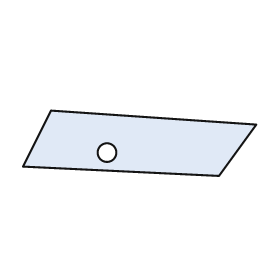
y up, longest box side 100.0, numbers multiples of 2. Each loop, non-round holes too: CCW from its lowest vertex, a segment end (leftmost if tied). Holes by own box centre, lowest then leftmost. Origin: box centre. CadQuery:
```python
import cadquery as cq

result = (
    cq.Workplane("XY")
    .moveTo(34.0, -14.0)
    .lineTo(50.0, 8.0)
    .lineTo(-38.0, 14.0)
    .lineTo(-50.0, -10.0)
    .close()
    .moveTo(-14.0, -4.0)
    .circle(4.0)
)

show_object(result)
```